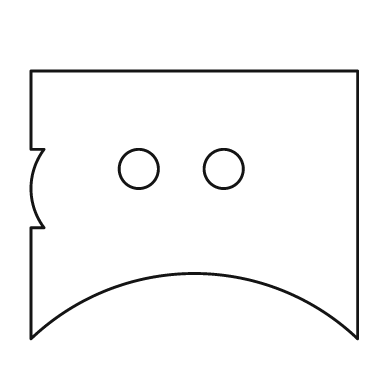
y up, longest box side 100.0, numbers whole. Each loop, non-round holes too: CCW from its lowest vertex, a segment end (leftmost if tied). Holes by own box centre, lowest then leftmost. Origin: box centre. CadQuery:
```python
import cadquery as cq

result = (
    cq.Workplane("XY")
    .moveTo(-50.0, -41.0)
    .threePointArc((0.0, -21.0), (50.0, -41.0))
    .lineTo(50.0, 41.0)
    .lineTo(-50.0, 41.0)
    .lineTo(-50.0, 17.0)
    .lineTo(-46.0, 17.0)
    .threePointArc((-50.0, 5.0), (-46.0, -7.0))
    .lineTo(-50.0, -7.0)
    .close()
    .moveTo(-17.0, 11.0)
    .circle(6.0)
    .moveTo(9.0, 11.0)
    .circle(6.0)
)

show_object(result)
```